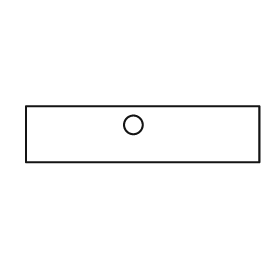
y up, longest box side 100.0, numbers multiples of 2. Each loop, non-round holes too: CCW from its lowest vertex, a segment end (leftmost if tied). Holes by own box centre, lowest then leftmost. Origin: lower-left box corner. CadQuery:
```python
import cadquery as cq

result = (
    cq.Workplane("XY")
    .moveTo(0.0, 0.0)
    .lineTo(100.0, 0.0)
    .lineTo(100.0, 24.0)
    .lineTo(0.0, 24.0)
    .close()
    .moveTo(46.0, 16.0)
    .circle(4.0)
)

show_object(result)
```